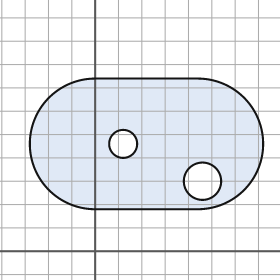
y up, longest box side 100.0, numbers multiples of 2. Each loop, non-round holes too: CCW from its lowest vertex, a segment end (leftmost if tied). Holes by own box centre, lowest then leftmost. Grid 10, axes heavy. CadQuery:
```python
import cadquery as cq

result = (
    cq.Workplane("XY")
    .moveTo(0.0, 18.0)
    .lineTo(44.0, 18.0)
    .threePointArc((72.0, 46.0), (44.0, 74.0))
    .lineTo(0.0, 74.0)
    .threePointArc((-28.0, 46.0), (0.0, 18.0))
    .close()
    .moveTo(46.0, 30.0)
    .circle(8.0)
    .moveTo(12.0, 46.0)
    .circle(6.0)
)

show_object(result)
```